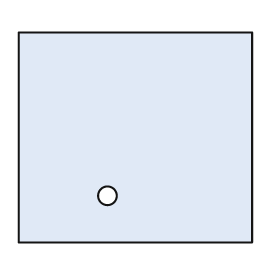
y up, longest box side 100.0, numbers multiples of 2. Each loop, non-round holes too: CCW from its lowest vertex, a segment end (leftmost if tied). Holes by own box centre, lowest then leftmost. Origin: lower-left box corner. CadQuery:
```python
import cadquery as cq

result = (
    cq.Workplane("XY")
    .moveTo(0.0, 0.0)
    .lineTo(100.0, 0.0)
    .lineTo(100.0, 90.0)
    .lineTo(0.0, 90.0)
    .close()
    .moveTo(38.0, 20.0)
    .circle(4.0)
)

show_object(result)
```